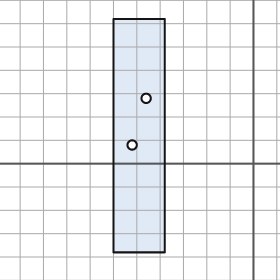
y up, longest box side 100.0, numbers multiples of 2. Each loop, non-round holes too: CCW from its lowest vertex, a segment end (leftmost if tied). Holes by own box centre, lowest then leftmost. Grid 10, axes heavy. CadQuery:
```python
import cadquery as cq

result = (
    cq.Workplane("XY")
    .moveTo(-60.0, -38.0)
    .lineTo(-38.0, -38.0)
    .lineTo(-38.0, 62.0)
    .lineTo(-60.0, 62.0)
    .close()
    .moveTo(-52.0, 8.0)
    .circle(2.0)
    .moveTo(-46.0, 28.0)
    .circle(2.0)
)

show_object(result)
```